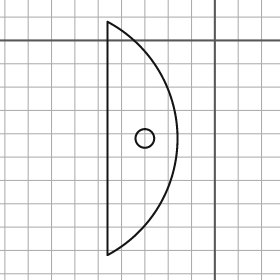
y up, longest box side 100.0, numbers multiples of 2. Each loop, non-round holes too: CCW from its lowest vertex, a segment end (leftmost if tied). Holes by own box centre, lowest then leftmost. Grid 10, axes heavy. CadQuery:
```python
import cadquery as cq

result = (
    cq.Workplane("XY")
    .moveTo(-46.0, -92.0)
    .threePointArc((-16.0, -42.0), (-46.0, 8.0))
    .close()
    .moveTo(-30.0, -42.0)
    .circle(4.0)
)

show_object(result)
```